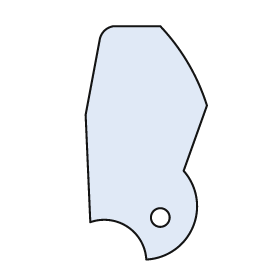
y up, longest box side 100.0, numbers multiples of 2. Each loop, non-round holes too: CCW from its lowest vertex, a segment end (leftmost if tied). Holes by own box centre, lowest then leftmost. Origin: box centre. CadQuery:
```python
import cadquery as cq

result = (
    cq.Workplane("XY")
    .moveTo(0.0, -50.0)
    .threePointArc((20.0, -36.0), (16.0, -12.0))
    .lineTo(26.0, 16.0)
    .threePointArc((18.0, 34.0), (6.0, 50.0))
    .lineTo(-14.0, 50.0)
    .threePointArc((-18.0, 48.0), (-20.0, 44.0))
    .lineTo(-26.0, 12.0)
    .lineTo(-24.0, -34.0)
    .threePointArc((-8.0, -36.0), (0.0, -50.0))
    .close()
    .moveTo(6.0, -32.0)
    .circle(4.0)
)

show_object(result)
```